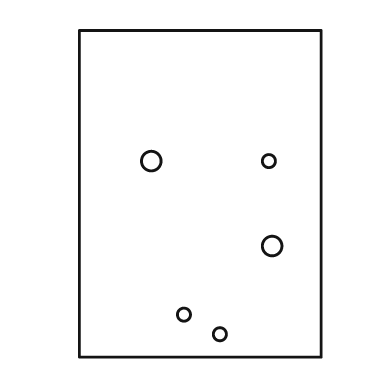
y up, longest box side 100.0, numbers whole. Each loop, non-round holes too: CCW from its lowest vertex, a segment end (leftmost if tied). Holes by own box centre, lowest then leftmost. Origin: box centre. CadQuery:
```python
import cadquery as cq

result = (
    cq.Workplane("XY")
    .moveTo(-37.0, -50.0)
    .lineTo(37.0, -50.0)
    .lineTo(37.0, 50.0)
    .lineTo(-37.0, 50.0)
    .close()
    .moveTo(6.0, -43.0)
    .circle(2.0)
    .moveTo(-5.0, -37.0)
    .circle(2.0)
    .moveTo(22.0, -16.0)
    .circle(3.0)
    .moveTo(-15.0, 10.0)
    .circle(3.0)
    .moveTo(21.0, 10.0)
    .circle(2.0)
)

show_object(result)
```